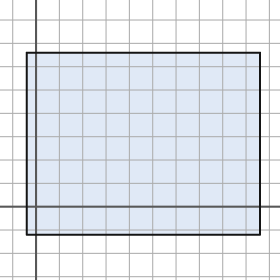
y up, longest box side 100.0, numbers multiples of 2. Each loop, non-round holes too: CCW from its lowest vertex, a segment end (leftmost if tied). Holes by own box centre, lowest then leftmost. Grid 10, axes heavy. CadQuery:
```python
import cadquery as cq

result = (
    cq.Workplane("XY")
    .moveTo(-4.0, -12.0)
    .lineTo(96.0, -12.0)
    .lineTo(96.0, 66.0)
    .lineTo(-4.0, 66.0)
    .close()
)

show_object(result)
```